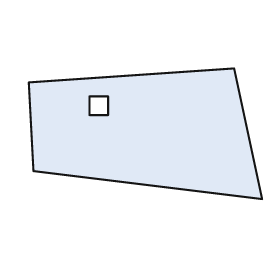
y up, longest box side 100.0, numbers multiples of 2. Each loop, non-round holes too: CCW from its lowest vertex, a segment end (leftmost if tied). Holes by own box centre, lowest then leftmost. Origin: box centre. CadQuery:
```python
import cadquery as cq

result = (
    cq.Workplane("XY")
    .moveTo(50.0, -28.0)
    .lineTo(38.0, 28.0)
    .lineTo(-50.0, 22.0)
    .lineTo(-48.0, -16.0)
    .close()
    .moveTo(-24.0, 8.0)
    .lineTo(-16.0, 8.0)
    .lineTo(-16.0, 16.0)
    .lineTo(-24.0, 16.0)
    .close()
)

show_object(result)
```